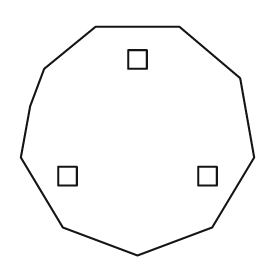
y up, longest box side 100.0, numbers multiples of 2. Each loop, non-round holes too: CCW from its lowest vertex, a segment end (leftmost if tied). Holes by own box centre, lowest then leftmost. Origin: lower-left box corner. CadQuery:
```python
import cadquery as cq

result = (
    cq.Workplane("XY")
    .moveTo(50.0, 0.0)
    .lineTo(82.0, 12.0)
    .lineTo(100.0, 42.0)
    .lineTo(94.0, 76.0)
    .lineTo(68.0, 98.0)
    .lineTo(32.0, 98.0)
    .lineTo(10.0, 80.0)
    .lineTo(4.0, 64.0)
    .lineTo(0.0, 42.0)
    .lineTo(18.0, 12.0)
    .close()
    .moveTo(16.0, 30.0)
    .lineTo(24.0, 30.0)
    .lineTo(24.0, 38.0)
    .lineTo(16.0, 38.0)
    .close()
    .moveTo(76.0, 30.0)
    .lineTo(84.0, 30.0)
    .lineTo(84.0, 38.0)
    .lineTo(76.0, 38.0)
    .close()
    .moveTo(46.0, 80.0)
    .lineTo(54.0, 80.0)
    .lineTo(54.0, 88.0)
    .lineTo(46.0, 88.0)
    .close()
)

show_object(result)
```